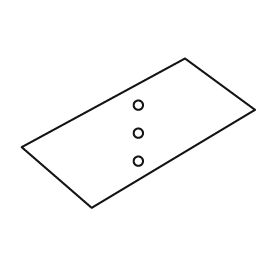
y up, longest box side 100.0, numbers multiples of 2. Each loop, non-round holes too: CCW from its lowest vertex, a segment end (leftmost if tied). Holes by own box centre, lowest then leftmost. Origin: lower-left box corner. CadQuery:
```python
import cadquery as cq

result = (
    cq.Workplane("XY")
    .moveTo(30.0, 0.0)
    .lineTo(100.0, 42.0)
    .lineTo(70.0, 64.0)
    .lineTo(0.0, 26.0)
    .close()
    .moveTo(50.0, 20.0)
    .circle(2.0)
    .moveTo(50.0, 32.0)
    .circle(2.0)
    .moveTo(50.0, 44.0)
    .circle(2.0)
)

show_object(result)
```